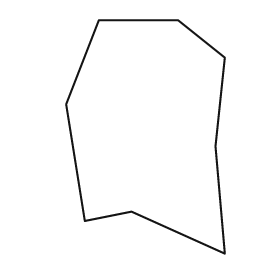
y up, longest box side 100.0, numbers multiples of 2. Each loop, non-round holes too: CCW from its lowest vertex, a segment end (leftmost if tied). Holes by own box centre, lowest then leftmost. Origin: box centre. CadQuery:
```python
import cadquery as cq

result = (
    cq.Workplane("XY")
    .moveTo(34.0, -50.0)
    .lineTo(30.0, -4.0)
    .lineTo(34.0, 34.0)
    .lineTo(14.0, 50.0)
    .lineTo(-20.0, 50.0)
    .lineTo(-34.0, 14.0)
    .lineTo(-26.0, -36.0)
    .lineTo(-6.0, -32.0)
    .close()
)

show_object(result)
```